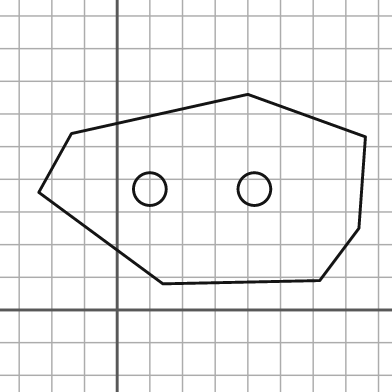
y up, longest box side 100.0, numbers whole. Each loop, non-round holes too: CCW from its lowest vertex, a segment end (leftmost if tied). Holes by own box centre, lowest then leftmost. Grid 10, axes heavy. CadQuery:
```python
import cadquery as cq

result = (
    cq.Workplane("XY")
    .moveTo(14.0, 8.0)
    .lineTo(62.0, 9.0)
    .lineTo(74.0, 25.0)
    .lineTo(76.0, 53.0)
    .lineTo(40.0, 66.0)
    .lineTo(-14.0, 54.0)
    .lineTo(-24.0, 36.0)
    .close()
    .moveTo(10.0, 37.0)
    .circle(5.0)
    .moveTo(42.0, 37.0)
    .circle(5.0)
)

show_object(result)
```